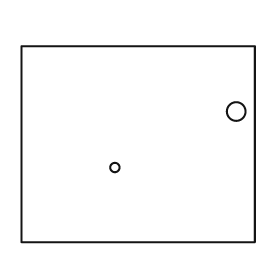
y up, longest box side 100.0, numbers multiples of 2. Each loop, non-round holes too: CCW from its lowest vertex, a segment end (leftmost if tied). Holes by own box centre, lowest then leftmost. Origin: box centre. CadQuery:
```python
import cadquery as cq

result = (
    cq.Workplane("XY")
    .moveTo(-50.0, -42.0)
    .lineTo(50.0, -42.0)
    .lineTo(50.0, 42.0)
    .lineTo(-50.0, 42.0)
    .close()
    .moveTo(-10.0, -10.0)
    .circle(2.0)
    .moveTo(42.0, 14.0)
    .circle(4.0)
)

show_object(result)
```